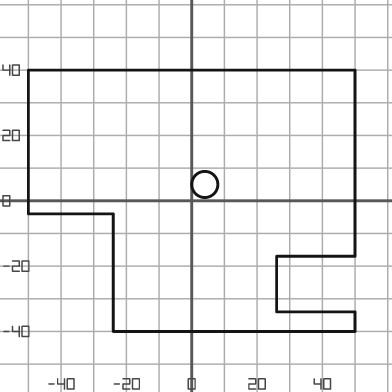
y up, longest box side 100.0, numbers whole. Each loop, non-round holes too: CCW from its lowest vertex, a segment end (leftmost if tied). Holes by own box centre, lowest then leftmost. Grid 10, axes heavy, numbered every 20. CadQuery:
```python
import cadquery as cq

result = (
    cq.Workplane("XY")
    .moveTo(-24.0, -40.0)
    .lineTo(50.0, -40.0)
    .lineTo(50.0, -34.0)
    .lineTo(26.0, -34.0)
    .lineTo(26.0, -17.0)
    .lineTo(50.0, -17.0)
    .lineTo(50.0, 40.0)
    .lineTo(-50.0, 40.0)
    .lineTo(-50.0, -4.0)
    .lineTo(-24.0, -4.0)
    .close()
    .moveTo(4.0, 5.0)
    .circle(4.0)
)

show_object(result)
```